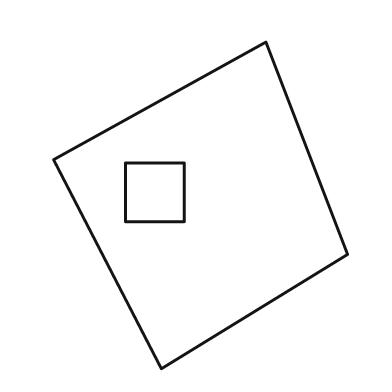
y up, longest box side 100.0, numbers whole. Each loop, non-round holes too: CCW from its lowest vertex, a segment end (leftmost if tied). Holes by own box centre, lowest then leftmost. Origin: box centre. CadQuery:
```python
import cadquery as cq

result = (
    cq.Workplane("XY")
    .moveTo(-12.0, -50.0)
    .lineTo(45.0, -15.0)
    .lineTo(20.0, 50.0)
    .lineTo(-45.0, 14.0)
    .close()
    .moveTo(-23.0, -5.0)
    .lineTo(-5.0, -5.0)
    .lineTo(-5.0, 13.0)
    .lineTo(-23.0, 13.0)
    .close()
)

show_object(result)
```